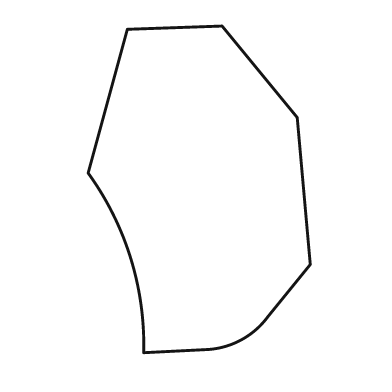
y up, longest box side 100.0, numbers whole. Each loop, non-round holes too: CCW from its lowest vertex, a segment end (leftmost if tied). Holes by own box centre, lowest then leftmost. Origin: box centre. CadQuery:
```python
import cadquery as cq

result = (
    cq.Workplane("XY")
    .moveTo(-17.0, -50.0)
    .lineTo(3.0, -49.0)
    .threePointArc((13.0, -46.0), (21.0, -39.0))
    .lineTo(34.0, -23.0)
    .lineTo(30.0, 22.0)
    .lineTo(7.0, 50.0)
    .lineTo(-22.0, 49.0)
    .lineTo(-34.0, 5.0)
    .threePointArc((-21.0, -21.0), (-17.0, -50.0))
    .close()
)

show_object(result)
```